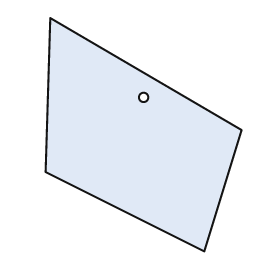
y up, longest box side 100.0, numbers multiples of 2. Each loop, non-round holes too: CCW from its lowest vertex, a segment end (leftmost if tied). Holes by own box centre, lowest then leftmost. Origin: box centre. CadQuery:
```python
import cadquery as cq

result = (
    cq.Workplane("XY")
    .moveTo(26.0, -50.0)
    .lineTo(42.0, 2.0)
    .lineTo(-40.0, 50.0)
    .lineTo(-42.0, -16.0)
    .close()
    .moveTo(0.0, 16.0)
    .circle(2.0)
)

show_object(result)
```